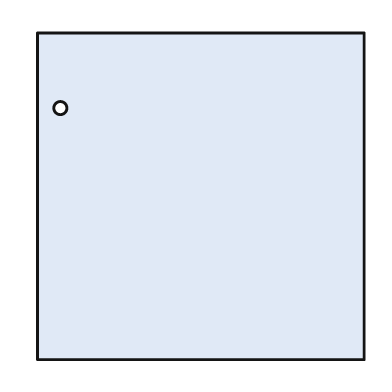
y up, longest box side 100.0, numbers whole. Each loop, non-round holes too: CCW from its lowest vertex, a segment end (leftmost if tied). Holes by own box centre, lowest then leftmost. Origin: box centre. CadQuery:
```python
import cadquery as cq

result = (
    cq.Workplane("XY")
    .moveTo(-50.0, -50.0)
    .lineTo(50.0, -50.0)
    .lineTo(50.0, 50.0)
    .lineTo(-50.0, 50.0)
    .close()
    .moveTo(-43.0, 27.0)
    .circle(2.0)
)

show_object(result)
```